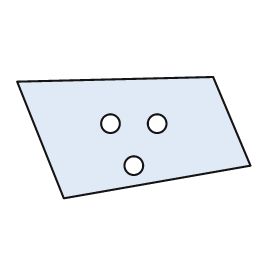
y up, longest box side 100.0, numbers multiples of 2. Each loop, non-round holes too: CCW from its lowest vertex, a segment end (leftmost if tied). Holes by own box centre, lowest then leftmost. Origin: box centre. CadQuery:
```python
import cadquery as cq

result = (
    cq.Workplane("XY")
    .moveTo(-30.0, -26.0)
    .lineTo(50.0, -12.0)
    .lineTo(34.0, 26.0)
    .lineTo(-50.0, 24.0)
    .close()
    .moveTo(0.0, -12.0)
    .circle(4.0)
    .moveTo(-10.0, 6.0)
    .circle(4.0)
    .moveTo(10.0, 6.0)
    .circle(4.0)
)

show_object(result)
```